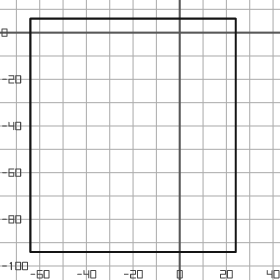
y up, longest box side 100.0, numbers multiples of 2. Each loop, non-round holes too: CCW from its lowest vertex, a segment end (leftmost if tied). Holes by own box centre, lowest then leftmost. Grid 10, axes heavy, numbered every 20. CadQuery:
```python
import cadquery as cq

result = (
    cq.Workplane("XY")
    .moveTo(-64.0, -94.0)
    .lineTo(24.0, -94.0)
    .lineTo(24.0, 6.0)
    .lineTo(-64.0, 6.0)
    .close()
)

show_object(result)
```